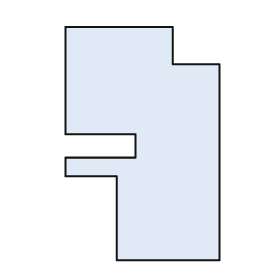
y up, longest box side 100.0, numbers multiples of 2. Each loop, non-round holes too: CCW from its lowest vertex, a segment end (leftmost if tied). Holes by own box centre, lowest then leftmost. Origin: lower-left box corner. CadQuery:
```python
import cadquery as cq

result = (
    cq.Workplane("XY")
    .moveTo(22.0, 0.0)
    .lineTo(66.0, 0.0)
    .lineTo(66.0, 84.0)
    .lineTo(46.0, 84.0)
    .lineTo(46.0, 100.0)
    .lineTo(0.0, 100.0)
    .lineTo(0.0, 54.0)
    .lineTo(30.0, 54.0)
    .lineTo(30.0, 44.0)
    .lineTo(0.0, 44.0)
    .lineTo(0.0, 36.0)
    .lineTo(22.0, 36.0)
    .close()
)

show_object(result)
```